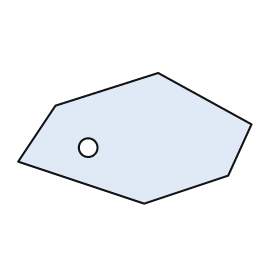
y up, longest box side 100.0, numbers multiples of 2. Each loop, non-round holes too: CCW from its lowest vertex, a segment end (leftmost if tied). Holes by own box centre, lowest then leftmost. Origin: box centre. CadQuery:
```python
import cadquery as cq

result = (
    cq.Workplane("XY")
    .moveTo(4.0, -28.0)
    .lineTo(40.0, -16.0)
    .lineTo(50.0, 6.0)
    .lineTo(10.0, 28.0)
    .lineTo(-34.0, 14.0)
    .lineTo(-50.0, -10.0)
    .close()
    .moveTo(-20.0, -4.0)
    .circle(4.0)
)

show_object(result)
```